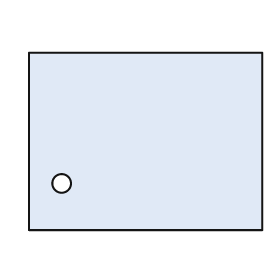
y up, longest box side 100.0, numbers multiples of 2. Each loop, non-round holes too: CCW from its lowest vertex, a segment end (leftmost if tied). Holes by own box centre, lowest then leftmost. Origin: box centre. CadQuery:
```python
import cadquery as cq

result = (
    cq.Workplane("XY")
    .moveTo(-50.0, -38.0)
    .lineTo(50.0, -38.0)
    .lineTo(50.0, 38.0)
    .lineTo(-50.0, 38.0)
    .close()
    .moveTo(-36.0, -18.0)
    .circle(4.0)
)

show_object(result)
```